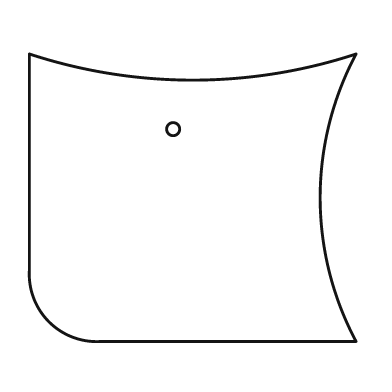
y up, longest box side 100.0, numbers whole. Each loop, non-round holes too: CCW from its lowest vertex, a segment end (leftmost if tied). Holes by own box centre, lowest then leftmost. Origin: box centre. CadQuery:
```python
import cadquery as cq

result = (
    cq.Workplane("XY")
    .moveTo(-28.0, -44.0)
    .lineTo(50.0, -44.0)
    .threePointArc((39.0, 0.0), (50.0, 44.0))
    .threePointArc((0.0, 36.0), (-50.0, 44.0))
    .lineTo(-50.0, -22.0)
    .threePointArc((-44.0, -38.0), (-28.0, -44.0))
    .close()
    .moveTo(-6.0, 21.0)
    .circle(2.0)
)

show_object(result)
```